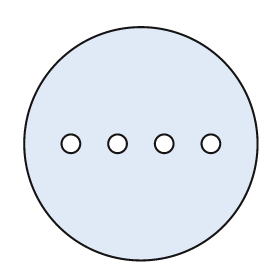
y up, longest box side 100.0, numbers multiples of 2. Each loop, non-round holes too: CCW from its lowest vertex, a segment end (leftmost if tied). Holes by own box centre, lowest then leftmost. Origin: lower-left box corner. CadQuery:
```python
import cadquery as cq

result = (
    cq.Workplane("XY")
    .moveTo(50.0, 50.0)
    .circle(50.0)
    .moveTo(20.0, 50.0)
    .circle(4.0)
    .moveTo(40.0, 50.0)
    .circle(4.0)
    .moveTo(60.0, 50.0)
    .circle(4.0)
    .moveTo(80.0, 50.0)
    .circle(4.0)
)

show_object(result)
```